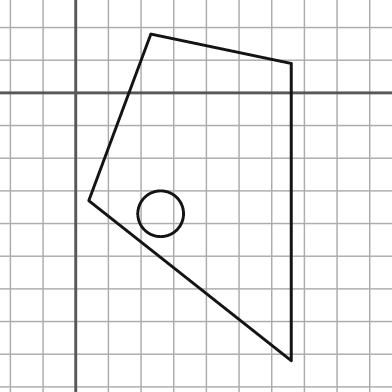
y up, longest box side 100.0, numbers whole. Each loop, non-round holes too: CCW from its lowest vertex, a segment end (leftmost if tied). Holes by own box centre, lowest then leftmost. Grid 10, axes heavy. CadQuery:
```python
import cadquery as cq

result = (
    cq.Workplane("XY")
    .moveTo(66.0, -82.0)
    .lineTo(66.0, 9.0)
    .lineTo(23.0, 18.0)
    .lineTo(4.0, -33.0)
    .close()
    .moveTo(26.0, -37.0)
    .circle(7.0)
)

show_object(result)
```